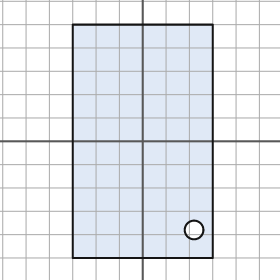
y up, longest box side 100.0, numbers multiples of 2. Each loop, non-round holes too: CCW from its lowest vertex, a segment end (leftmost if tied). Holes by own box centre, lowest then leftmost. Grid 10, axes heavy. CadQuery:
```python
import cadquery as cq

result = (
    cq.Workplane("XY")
    .moveTo(-30.0, -50.0)
    .lineTo(30.0, -50.0)
    .lineTo(30.0, 50.0)
    .lineTo(-30.0, 50.0)
    .close()
    .moveTo(22.0, -38.0)
    .circle(4.0)
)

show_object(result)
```